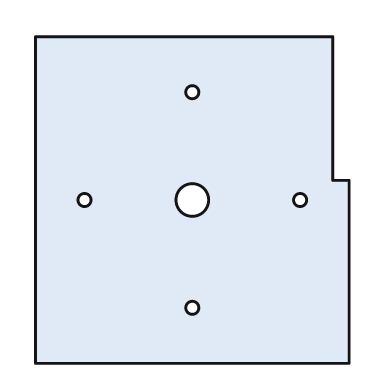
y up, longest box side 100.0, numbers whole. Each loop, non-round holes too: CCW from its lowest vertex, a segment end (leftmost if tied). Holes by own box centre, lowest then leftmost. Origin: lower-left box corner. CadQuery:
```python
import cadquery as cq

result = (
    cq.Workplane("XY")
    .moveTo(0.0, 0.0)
    .lineTo(96.0, 0.0)
    .lineTo(96.0, 56.0)
    .lineTo(91.0, 56.0)
    .lineTo(91.0, 100.0)
    .lineTo(0.0, 100.0)
    .close()
    .moveTo(48.0, 17.0)
    .circle(2.0)
    .moveTo(15.0, 50.0)
    .circle(2.0)
    .moveTo(48.0, 50.0)
    .circle(5.0)
    .moveTo(81.0, 50.0)
    .circle(2.0)
    .moveTo(48.0, 83.0)
    .circle(2.0)
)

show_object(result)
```